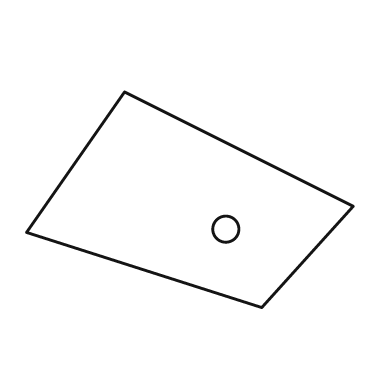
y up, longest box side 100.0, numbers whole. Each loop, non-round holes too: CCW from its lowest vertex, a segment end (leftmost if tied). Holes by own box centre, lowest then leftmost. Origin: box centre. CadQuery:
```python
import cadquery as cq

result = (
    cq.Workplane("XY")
    .moveTo(22.0, -33.0)
    .lineTo(50.0, -2.0)
    .lineTo(-20.0, 33.0)
    .lineTo(-50.0, -10.0)
    .close()
    .moveTo(11.0, -9.0)
    .circle(4.0)
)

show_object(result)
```